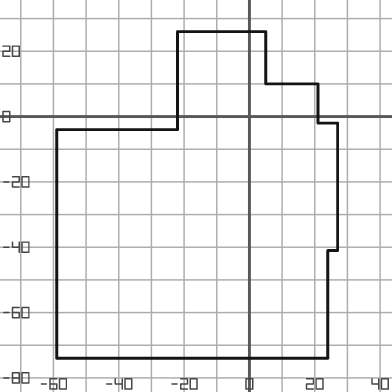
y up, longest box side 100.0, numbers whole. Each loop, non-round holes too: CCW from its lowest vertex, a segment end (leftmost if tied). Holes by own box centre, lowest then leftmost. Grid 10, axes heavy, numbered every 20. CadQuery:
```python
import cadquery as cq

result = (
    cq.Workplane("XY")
    .moveTo(-59.0, -74.0)
    .lineTo(24.0, -74.0)
    .lineTo(24.0, -41.0)
    .lineTo(27.0, -41.0)
    .lineTo(27.0, -2.0)
    .lineTo(21.0, -2.0)
    .lineTo(21.0, 10.0)
    .lineTo(5.0, 10.0)
    .lineTo(5.0, 26.0)
    .lineTo(-22.0, 26.0)
    .lineTo(-22.0, -4.0)
    .lineTo(-59.0, -4.0)
    .close()
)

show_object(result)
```